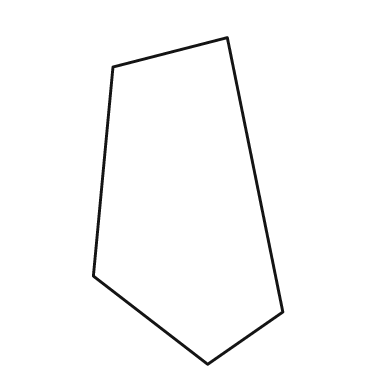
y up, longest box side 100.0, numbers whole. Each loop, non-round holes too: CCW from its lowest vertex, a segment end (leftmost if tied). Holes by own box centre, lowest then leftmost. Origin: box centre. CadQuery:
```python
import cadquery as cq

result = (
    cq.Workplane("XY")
    .moveTo(6.0, -50.0)
    .lineTo(29.0, -34.0)
    .lineTo(12.0, 50.0)
    .lineTo(-23.0, 41.0)
    .lineTo(-29.0, -23.0)
    .close()
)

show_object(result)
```